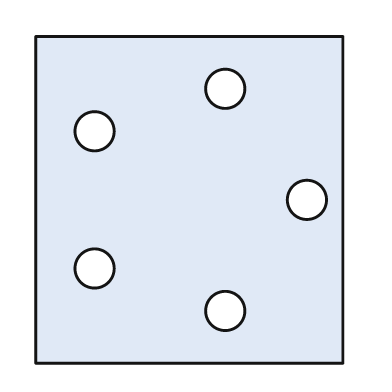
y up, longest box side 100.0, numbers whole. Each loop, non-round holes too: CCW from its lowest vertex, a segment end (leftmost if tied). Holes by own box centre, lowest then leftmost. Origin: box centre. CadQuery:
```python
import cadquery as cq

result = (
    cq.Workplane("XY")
    .moveTo(-47.0, -50.0)
    .lineTo(47.0, -50.0)
    .lineTo(47.0, 50.0)
    .lineTo(-47.0, 50.0)
    .close()
    .moveTo(11.0, -34.0)
    .circle(6.0)
    .moveTo(-29.0, -21.0)
    .circle(6.0)
    .moveTo(36.0, 0.0)
    .circle(6.0)
    .moveTo(-29.0, 21.0)
    .circle(6.0)
    .moveTo(11.0, 34.0)
    .circle(6.0)
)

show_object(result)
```